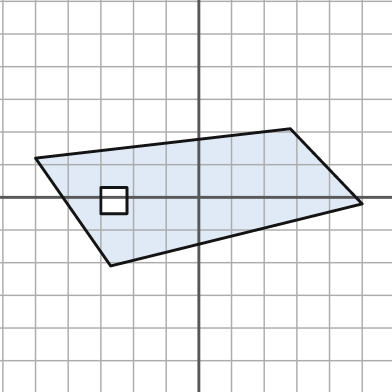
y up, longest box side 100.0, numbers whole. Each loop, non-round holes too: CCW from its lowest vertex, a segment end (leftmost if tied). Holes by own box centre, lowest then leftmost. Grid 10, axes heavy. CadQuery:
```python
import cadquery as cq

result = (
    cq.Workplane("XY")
    .moveTo(-27.0, -21.0)
    .lineTo(50.0, -2.0)
    .lineTo(28.0, 21.0)
    .lineTo(-50.0, 12.0)
    .close()
    .moveTo(-30.0, -5.0)
    .lineTo(-22.0, -5.0)
    .lineTo(-22.0, 3.0)
    .lineTo(-30.0, 3.0)
    .close()
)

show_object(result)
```